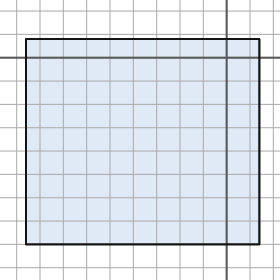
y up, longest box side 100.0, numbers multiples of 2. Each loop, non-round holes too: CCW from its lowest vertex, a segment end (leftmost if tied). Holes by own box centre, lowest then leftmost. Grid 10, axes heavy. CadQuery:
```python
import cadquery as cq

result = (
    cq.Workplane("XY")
    .moveTo(-86.0, -80.0)
    .lineTo(14.0, -80.0)
    .lineTo(14.0, 8.0)
    .lineTo(-86.0, 8.0)
    .close()
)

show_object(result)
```